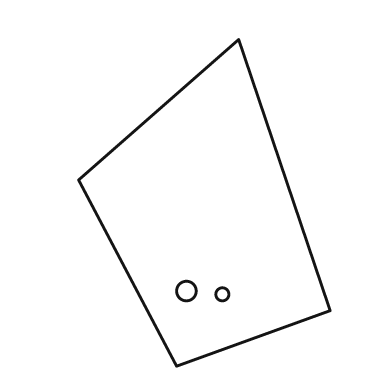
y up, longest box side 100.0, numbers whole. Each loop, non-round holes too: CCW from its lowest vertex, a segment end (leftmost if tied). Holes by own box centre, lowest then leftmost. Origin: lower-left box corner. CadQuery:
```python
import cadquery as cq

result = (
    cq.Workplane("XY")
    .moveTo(30.0, 0.0)
    .lineTo(77.0, 17.0)
    .lineTo(49.0, 100.0)
    .lineTo(0.0, 57.0)
    .close()
    .moveTo(44.0, 22.0)
    .circle(2.0)
    .moveTo(33.0, 23.0)
    .circle(3.0)
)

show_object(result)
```